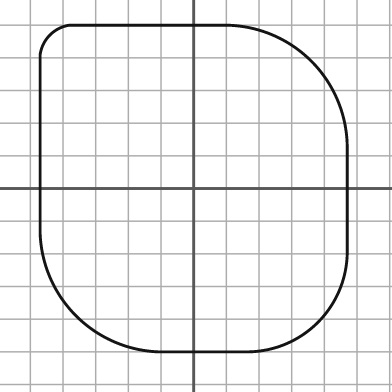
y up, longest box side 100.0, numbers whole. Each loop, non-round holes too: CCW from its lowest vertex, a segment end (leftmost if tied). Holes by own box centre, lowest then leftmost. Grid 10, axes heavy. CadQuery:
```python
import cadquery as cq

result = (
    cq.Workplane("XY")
    .moveTo(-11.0, -50.0)
    .lineTo(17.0, -50.0)
    .threePointArc((38.0, -41.0), (47.0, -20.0))
    .lineTo(47.0, 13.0)
    .threePointArc((36.0, 39.0), (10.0, 50.0))
    .lineTo(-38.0, 50.0)
    .threePointArc((-44.0, 47.0), (-47.0, 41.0))
    .lineTo(-47.0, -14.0)
    .threePointArc((-36.0, -39.0), (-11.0, -50.0))
    .close()
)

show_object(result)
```